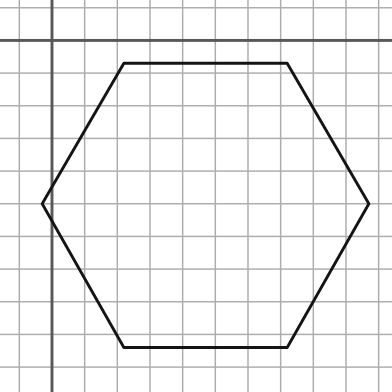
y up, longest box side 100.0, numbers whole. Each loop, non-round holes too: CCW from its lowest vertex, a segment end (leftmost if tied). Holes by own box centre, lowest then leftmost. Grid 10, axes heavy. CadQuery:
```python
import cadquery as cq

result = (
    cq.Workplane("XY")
    .moveTo(22.0, -94.0)
    .lineTo(72.0, -94.0)
    .lineTo(97.0, -50.0)
    .lineTo(72.0, -7.0)
    .lineTo(22.0, -7.0)
    .lineTo(-3.0, -50.0)
    .close()
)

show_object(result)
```